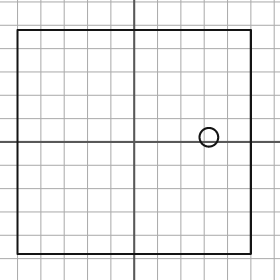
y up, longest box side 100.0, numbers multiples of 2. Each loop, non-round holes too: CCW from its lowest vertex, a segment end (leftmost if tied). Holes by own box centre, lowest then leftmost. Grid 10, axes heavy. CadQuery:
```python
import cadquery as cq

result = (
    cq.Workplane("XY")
    .moveTo(-50.0, -48.0)
    .lineTo(50.0, -48.0)
    .lineTo(50.0, 48.0)
    .lineTo(-50.0, 48.0)
    .close()
    .moveTo(32.0, 2.0)
    .circle(4.0)
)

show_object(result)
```